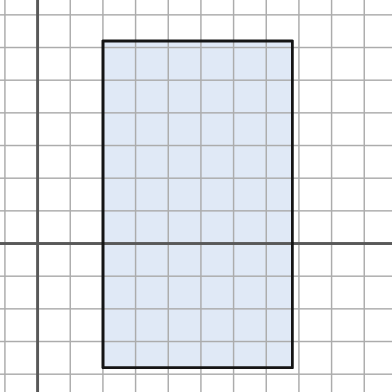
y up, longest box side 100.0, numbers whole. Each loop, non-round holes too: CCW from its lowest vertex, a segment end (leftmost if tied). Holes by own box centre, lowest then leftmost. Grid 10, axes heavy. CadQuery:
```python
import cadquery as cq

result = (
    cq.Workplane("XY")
    .moveTo(20.0, -38.0)
    .lineTo(78.0, -38.0)
    .lineTo(78.0, 62.0)
    .lineTo(20.0, 62.0)
    .close()
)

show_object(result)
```